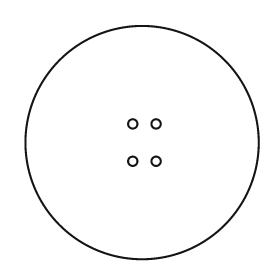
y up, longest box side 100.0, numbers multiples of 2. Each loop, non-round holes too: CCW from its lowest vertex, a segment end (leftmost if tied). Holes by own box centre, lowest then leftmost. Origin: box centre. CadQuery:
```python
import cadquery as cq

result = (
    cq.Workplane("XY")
    .moveTo(0.0, 0.0)
    .circle(50.0)
    .moveTo(-4.0, -8.0)
    .circle(2.0)
    .moveTo(6.0, -8.0)
    .circle(2.0)
    .moveTo(-4.0, 8.0)
    .circle(2.0)
    .moveTo(6.0, 8.0)
    .circle(2.0)
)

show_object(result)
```